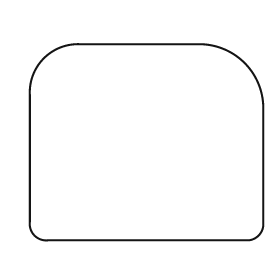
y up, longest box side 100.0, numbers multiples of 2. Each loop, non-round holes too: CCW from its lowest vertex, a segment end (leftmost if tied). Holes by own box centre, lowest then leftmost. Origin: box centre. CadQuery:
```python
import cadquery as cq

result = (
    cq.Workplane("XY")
    .moveTo(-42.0, -42.0)
    .lineTo(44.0, -42.0)
    .threePointArc((48.0, -40.0), (50.0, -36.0))
    .lineTo(50.0, 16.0)
    .threePointArc((42.0, 34.0), (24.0, 42.0))
    .lineTo(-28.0, 42.0)
    .threePointArc((-44.0, 36.0), (-50.0, 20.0))
    .lineTo(-50.0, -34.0)
    .threePointArc((-48.0, -40.0), (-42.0, -42.0))
    .close()
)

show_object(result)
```